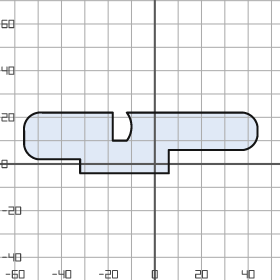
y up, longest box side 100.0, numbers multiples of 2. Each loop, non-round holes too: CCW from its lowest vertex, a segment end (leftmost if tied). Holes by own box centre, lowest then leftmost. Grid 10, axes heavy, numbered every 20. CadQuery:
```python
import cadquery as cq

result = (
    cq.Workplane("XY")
    .moveTo(-32.0, -4.0)
    .lineTo(6.0, -4.0)
    .lineTo(6.0, 6.0)
    .lineTo(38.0, 6.0)
    .threePointArc((42.0, 8.0), (44.0, 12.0))
    .lineTo(44.0, 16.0)
    .threePointArc((42.0, 20.0), (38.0, 22.0))
    .lineTo(-12.0, 22.0)
    .threePointArc((-10.0, 16.0), (-12.0, 10.0))
    .lineTo(-18.0, 10.0)
    .lineTo(-18.0, 22.0)
    .lineTo(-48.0, 22.0)
    .threePointArc((-54.0, 20.0), (-56.0, 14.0))
    .lineTo(-56.0, 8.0)
    .threePointArc((-54.0, 4.0), (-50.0, 2.0))
    .lineTo(-32.0, 2.0)
    .close()
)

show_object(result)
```